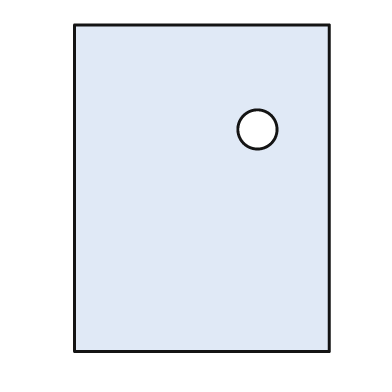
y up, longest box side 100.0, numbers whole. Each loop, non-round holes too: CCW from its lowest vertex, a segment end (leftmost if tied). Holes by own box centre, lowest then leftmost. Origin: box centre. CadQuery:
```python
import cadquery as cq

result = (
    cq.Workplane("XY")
    .moveTo(-39.0, -50.0)
    .lineTo(39.0, -50.0)
    .lineTo(39.0, 50.0)
    .lineTo(-39.0, 50.0)
    .close()
    .moveTo(17.0, 18.0)
    .circle(6.0)
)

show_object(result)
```